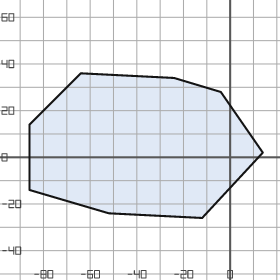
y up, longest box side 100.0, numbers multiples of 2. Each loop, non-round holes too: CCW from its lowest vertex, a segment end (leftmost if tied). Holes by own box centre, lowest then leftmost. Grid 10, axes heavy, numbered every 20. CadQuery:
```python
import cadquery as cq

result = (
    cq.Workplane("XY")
    .moveTo(-12.0, -26.0)
    .lineTo(14.0, 2.0)
    .lineTo(-4.0, 28.0)
    .lineTo(-24.0, 34.0)
    .lineTo(-64.0, 36.0)
    .lineTo(-86.0, 14.0)
    .lineTo(-86.0, -14.0)
    .lineTo(-52.0, -24.0)
    .close()
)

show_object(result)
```